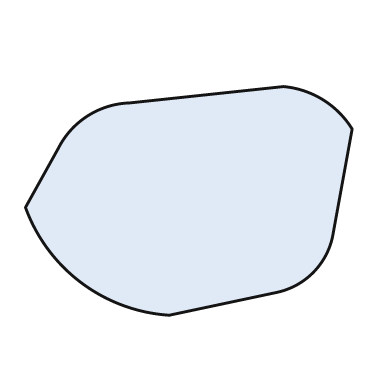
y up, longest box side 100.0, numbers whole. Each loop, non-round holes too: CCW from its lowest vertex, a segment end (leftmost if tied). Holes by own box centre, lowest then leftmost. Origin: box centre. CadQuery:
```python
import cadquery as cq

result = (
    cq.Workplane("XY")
    .moveTo(-6.0, -35.0)
    .lineTo(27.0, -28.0)
    .threePointArc((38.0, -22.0), (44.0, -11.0))
    .lineTo(50.0, 22.0)
    .threePointArc((41.0, 31.0), (29.0, 35.0))
    .lineTo(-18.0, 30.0)
    .threePointArc((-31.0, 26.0), (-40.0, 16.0))
    .lineTo(-50.0, -2.0)
    .threePointArc((-33.0, -25.0), (-6.0, -35.0))
    .close()
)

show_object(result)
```